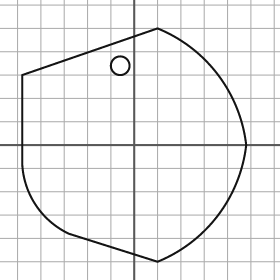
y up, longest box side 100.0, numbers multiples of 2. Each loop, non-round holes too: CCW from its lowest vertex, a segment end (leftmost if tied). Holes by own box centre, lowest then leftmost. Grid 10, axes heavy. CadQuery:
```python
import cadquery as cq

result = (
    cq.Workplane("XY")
    .moveTo(10.0, -50.0)
    .threePointArc((36.0, -30.0), (48.0, 0.0))
    .threePointArc((36.0, 30.0), (10.0, 50.0))
    .lineTo(-48.0, 30.0)
    .lineTo(-48.0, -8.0)
    .threePointArc((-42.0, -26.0), (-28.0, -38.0))
    .close()
    .moveTo(-6.0, 34.0)
    .circle(4.0)
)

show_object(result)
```